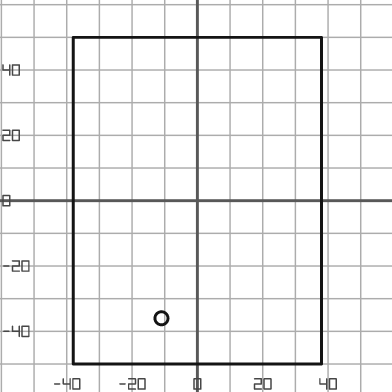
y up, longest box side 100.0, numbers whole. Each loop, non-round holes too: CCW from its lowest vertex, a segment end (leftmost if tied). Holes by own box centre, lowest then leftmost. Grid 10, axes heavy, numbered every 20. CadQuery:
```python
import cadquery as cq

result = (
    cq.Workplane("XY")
    .moveTo(-38.0, -50.0)
    .lineTo(38.0, -50.0)
    .lineTo(38.0, 50.0)
    .lineTo(-38.0, 50.0)
    .close()
    .moveTo(-11.0, -36.0)
    .circle(2.0)
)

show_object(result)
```